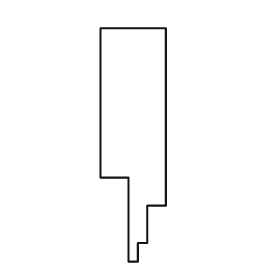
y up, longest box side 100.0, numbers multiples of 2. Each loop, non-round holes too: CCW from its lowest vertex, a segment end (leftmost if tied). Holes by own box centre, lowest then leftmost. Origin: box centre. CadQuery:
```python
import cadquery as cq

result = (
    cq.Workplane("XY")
    .moveTo(-2.0, -50.0)
    .lineTo(2.0, -50.0)
    .lineTo(2.0, -42.0)
    .lineTo(6.0, -42.0)
    .lineTo(6.0, -26.0)
    .lineTo(14.0, -26.0)
    .lineTo(14.0, 50.0)
    .lineTo(-14.0, 50.0)
    .lineTo(-14.0, -14.0)
    .lineTo(-2.0, -14.0)
    .close()
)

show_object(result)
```